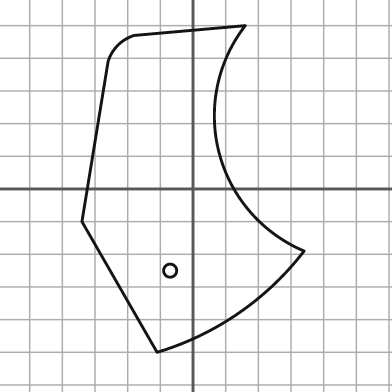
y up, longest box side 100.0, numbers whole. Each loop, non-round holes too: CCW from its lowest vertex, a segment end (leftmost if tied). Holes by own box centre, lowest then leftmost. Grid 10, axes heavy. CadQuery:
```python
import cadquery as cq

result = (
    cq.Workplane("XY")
    .moveTo(-11.0, -50.0)
    .threePointArc((14.0, -38.0), (34.0, -19.0))
    .threePointArc((8.0, 11.0), (16.0, 50.0))
    .lineTo(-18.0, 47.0)
    .threePointArc((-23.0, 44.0), (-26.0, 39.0))
    .lineTo(-34.0, -10.0)
    .close()
    .moveTo(-7.0, -25.0)
    .circle(2.0)
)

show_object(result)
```